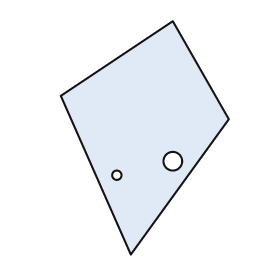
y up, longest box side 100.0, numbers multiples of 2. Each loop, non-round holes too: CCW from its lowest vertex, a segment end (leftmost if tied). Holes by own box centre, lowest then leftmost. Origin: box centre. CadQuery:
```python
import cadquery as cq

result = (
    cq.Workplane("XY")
    .moveTo(-6.0, -50.0)
    .lineTo(36.0, 8.0)
    .lineTo(12.0, 50.0)
    .lineTo(-36.0, 18.0)
    .close()
    .moveTo(-12.0, -16.0)
    .circle(2.0)
    .moveTo(12.0, -10.0)
    .circle(4.0)
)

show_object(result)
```